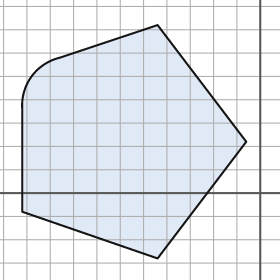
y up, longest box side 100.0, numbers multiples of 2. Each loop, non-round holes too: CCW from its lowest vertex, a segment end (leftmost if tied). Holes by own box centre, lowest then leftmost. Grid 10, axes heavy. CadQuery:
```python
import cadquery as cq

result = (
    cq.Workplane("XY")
    .moveTo(-44.0, -28.0)
    .lineTo(-6.0, 22.0)
    .lineTo(-44.0, 72.0)
    .lineTo(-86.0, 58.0)
    .threePointArc((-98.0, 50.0), (-102.0, 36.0))
    .lineTo(-102.0, -8.0)
    .close()
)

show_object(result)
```